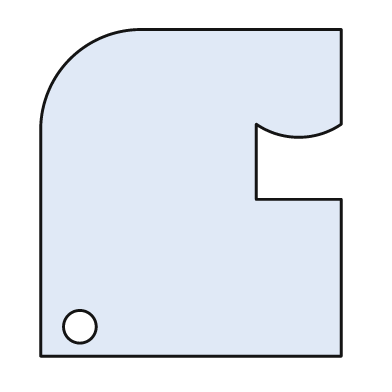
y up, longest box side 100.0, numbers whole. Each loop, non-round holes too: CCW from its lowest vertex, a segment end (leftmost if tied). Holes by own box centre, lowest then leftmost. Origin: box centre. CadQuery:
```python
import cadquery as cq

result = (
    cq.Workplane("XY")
    .moveTo(-46.0, -50.0)
    .lineTo(46.0, -50.0)
    .lineTo(46.0, -2.0)
    .lineTo(20.0, -2.0)
    .lineTo(20.0, 21.0)
    .threePointArc((33.0, 17.0), (46.0, 21.0))
    .lineTo(46.0, 50.0)
    .lineTo(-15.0, 50.0)
    .threePointArc((-37.0, 41.0), (-46.0, 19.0))
    .close()
    .moveTo(-34.0, -41.0)
    .circle(5.0)
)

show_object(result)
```